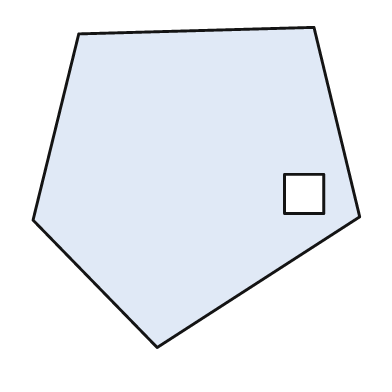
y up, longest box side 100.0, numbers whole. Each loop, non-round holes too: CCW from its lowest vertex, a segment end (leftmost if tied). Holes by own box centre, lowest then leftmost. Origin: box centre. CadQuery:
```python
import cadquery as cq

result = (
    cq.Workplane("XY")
    .moveTo(-12.0, -49.0)
    .lineTo(50.0, -9.0)
    .lineTo(36.0, 49.0)
    .lineTo(-36.0, 47.0)
    .lineTo(-50.0, -10.0)
    .close()
    .moveTo(27.0, -8.0)
    .lineTo(39.0, -8.0)
    .lineTo(39.0, 4.0)
    .lineTo(27.0, 4.0)
    .close()
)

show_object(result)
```